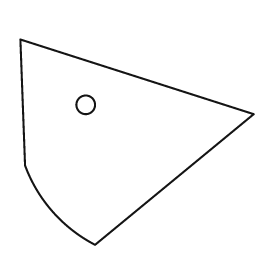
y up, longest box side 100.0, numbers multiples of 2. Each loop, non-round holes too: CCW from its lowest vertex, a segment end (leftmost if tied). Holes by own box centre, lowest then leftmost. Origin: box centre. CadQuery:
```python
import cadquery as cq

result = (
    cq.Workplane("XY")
    .moveTo(-18.0, -44.0)
    .lineTo(50.0, 12.0)
    .lineTo(-50.0, 44.0)
    .lineTo(-48.0, -10.0)
    .threePointArc((-36.0, -30.0), (-18.0, -44.0))
    .close()
    .moveTo(-22.0, 16.0)
    .circle(4.0)
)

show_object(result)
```